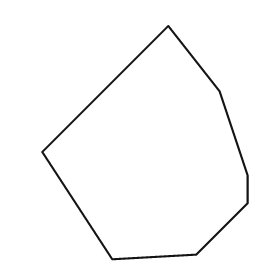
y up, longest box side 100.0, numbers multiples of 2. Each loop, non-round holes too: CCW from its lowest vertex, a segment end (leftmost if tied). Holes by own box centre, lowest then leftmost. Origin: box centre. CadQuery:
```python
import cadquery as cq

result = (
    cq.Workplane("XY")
    .moveTo(-14.0, -50.0)
    .lineTo(22.0, -48.0)
    .lineTo(44.0, -26.0)
    .lineTo(44.0, -14.0)
    .lineTo(32.0, 22.0)
    .lineTo(10.0, 50.0)
    .lineTo(-44.0, -4.0)
    .close()
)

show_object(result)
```